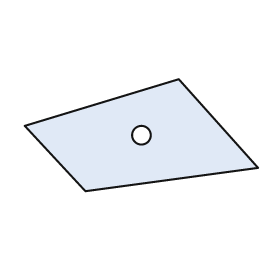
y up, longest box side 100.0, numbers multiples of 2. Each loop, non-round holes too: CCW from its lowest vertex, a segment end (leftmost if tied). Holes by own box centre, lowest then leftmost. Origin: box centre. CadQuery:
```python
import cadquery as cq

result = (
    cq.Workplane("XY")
    .moveTo(-24.0, -24.0)
    .lineTo(50.0, -14.0)
    .lineTo(16.0, 24.0)
    .lineTo(-50.0, 4.0)
    .close()
    .moveTo(0.0, 0.0)
    .circle(4.0)
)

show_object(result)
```